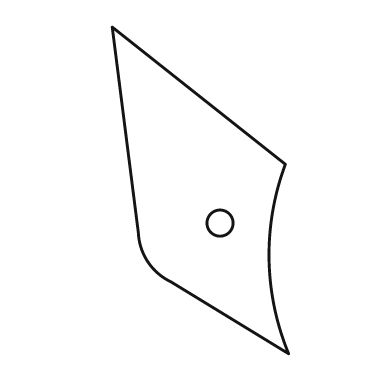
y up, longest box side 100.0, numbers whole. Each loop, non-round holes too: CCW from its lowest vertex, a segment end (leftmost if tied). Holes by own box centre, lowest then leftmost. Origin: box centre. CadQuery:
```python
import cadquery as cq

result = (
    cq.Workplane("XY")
    .moveTo(27.0, -50.0)
    .threePointArc((21.0, -21.0), (26.0, 8.0))
    .lineTo(-27.0, 50.0)
    .lineTo(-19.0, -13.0)
    .threePointArc((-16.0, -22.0), (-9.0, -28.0))
    .close()
    .moveTo(6.0, -10.0)
    .circle(4.0)
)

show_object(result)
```